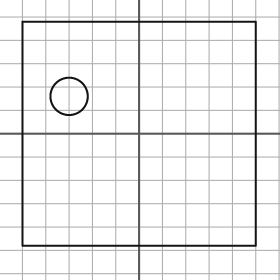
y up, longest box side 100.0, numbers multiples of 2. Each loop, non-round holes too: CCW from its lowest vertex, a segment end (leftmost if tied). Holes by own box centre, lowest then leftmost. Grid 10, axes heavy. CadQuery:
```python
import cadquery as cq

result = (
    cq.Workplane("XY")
    .moveTo(-50.0, -48.0)
    .lineTo(50.0, -48.0)
    .lineTo(50.0, 48.0)
    .lineTo(-50.0, 48.0)
    .close()
    .moveTo(-30.0, 16.0)
    .circle(8.0)
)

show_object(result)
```